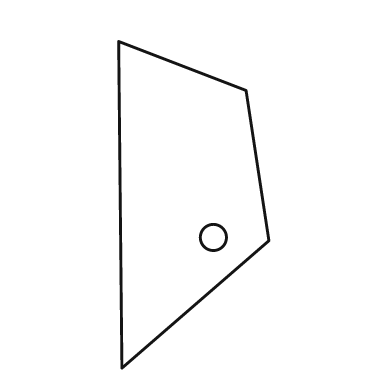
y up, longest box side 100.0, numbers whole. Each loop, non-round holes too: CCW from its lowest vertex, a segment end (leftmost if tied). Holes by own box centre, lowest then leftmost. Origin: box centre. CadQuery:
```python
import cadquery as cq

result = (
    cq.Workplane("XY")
    .moveTo(-22.0, -50.0)
    .lineTo(23.0, -11.0)
    .lineTo(16.0, 35.0)
    .lineTo(-23.0, 50.0)
    .close()
    .moveTo(6.0, -10.0)
    .circle(4.0)
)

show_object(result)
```